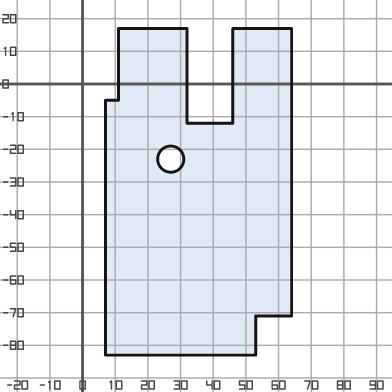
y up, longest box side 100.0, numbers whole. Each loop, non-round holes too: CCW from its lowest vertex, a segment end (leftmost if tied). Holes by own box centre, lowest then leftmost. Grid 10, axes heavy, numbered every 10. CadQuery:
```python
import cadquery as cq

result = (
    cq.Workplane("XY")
    .moveTo(7.0, -83.0)
    .lineTo(53.0, -83.0)
    .lineTo(53.0, -71.0)
    .lineTo(64.0, -71.0)
    .lineTo(64.0, 17.0)
    .lineTo(46.0, 17.0)
    .lineTo(46.0, -12.0)
    .lineTo(32.0, -12.0)
    .lineTo(32.0, 17.0)
    .lineTo(11.0, 17.0)
    .lineTo(11.0, -5.0)
    .lineTo(7.0, -5.0)
    .close()
    .moveTo(27.0, -23.0)
    .circle(4.0)
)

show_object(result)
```